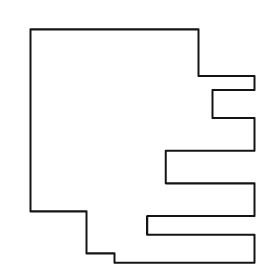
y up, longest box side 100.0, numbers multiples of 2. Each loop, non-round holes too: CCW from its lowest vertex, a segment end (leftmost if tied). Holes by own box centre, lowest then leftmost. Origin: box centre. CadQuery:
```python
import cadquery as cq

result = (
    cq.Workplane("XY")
    .moveTo(-12.0, -50.0)
    .lineTo(48.0, -50.0)
    .lineTo(48.0, -38.0)
    .lineTo(2.0, -38.0)
    .lineTo(2.0, -30.0)
    .lineTo(48.0, -30.0)
    .lineTo(48.0, -16.0)
    .lineTo(10.0, -16.0)
    .lineTo(10.0, -2.0)
    .lineTo(48.0, -2.0)
    .lineTo(48.0, 12.0)
    .lineTo(30.0, 12.0)
    .lineTo(30.0, 24.0)
    .lineTo(48.0, 24.0)
    .lineTo(48.0, 30.0)
    .lineTo(24.0, 30.0)
    .lineTo(24.0, 50.0)
    .lineTo(-48.0, 50.0)
    .lineTo(-48.0, -28.0)
    .lineTo(-24.0, -28.0)
    .lineTo(-24.0, -46.0)
    .lineTo(-12.0, -46.0)
    .close()
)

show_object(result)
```